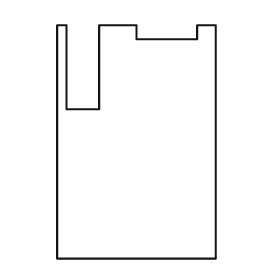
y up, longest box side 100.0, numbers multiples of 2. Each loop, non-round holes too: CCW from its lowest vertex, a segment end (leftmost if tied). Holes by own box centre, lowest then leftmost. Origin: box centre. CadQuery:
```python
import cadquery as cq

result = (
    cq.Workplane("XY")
    .moveTo(-34.0, -50.0)
    .lineTo(34.0, -50.0)
    .lineTo(34.0, 50.0)
    .lineTo(26.0, 50.0)
    .lineTo(26.0, 44.0)
    .lineTo(0.0, 44.0)
    .lineTo(0.0, 50.0)
    .lineTo(-16.0, 50.0)
    .lineTo(-16.0, 14.0)
    .lineTo(-30.0, 14.0)
    .lineTo(-30.0, 50.0)
    .lineTo(-34.0, 50.0)
    .close()
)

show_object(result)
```